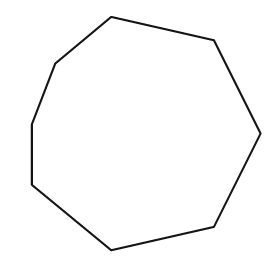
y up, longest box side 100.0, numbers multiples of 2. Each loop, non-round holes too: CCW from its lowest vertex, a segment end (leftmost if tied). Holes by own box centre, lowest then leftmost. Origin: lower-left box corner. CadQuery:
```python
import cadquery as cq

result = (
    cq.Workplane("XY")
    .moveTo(34.0, 0.0)
    .lineTo(78.0, 10.0)
    .lineTo(98.0, 50.0)
    .lineTo(78.0, 90.0)
    .lineTo(34.0, 100.0)
    .lineTo(10.0, 80.0)
    .lineTo(0.0, 54.0)
    .lineTo(0.0, 28.0)
    .close()
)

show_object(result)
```